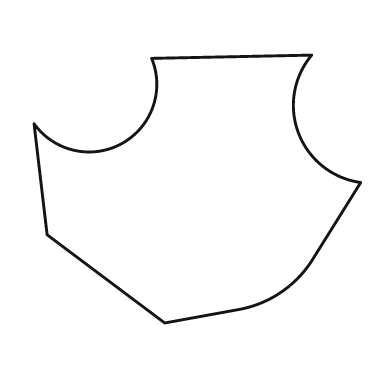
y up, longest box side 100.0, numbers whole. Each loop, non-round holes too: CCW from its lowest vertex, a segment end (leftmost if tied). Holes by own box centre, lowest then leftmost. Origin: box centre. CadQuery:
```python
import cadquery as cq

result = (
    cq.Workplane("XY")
    .moveTo(-10.0, -41.0)
    .lineTo(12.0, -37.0)
    .threePointArc((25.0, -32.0), (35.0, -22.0))
    .lineTo(50.0, 2.0)
    .threePointArc((31.0, 17.0), (35.0, 41.0))
    .lineTo(-14.0, 40.0)
    .threePointArc((-23.0, 14.0), (-50.0, 20.0))
    .lineTo(-46.0, -14.0)
    .close()
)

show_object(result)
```